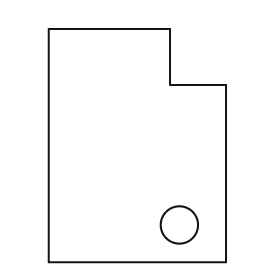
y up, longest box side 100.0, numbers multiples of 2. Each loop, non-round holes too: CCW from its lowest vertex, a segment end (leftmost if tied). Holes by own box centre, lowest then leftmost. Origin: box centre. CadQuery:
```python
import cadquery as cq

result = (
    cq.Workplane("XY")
    .moveTo(-38.0, -50.0)
    .lineTo(38.0, -50.0)
    .lineTo(38.0, 26.0)
    .lineTo(14.0, 26.0)
    .lineTo(14.0, 50.0)
    .lineTo(-38.0, 50.0)
    .close()
    .moveTo(18.0, -34.0)
    .circle(8.0)
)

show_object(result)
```